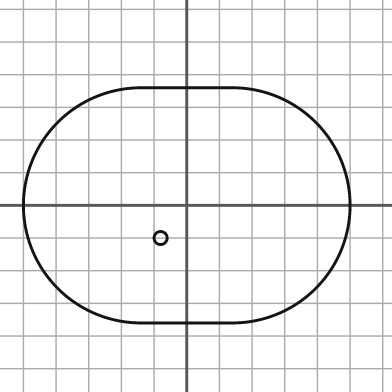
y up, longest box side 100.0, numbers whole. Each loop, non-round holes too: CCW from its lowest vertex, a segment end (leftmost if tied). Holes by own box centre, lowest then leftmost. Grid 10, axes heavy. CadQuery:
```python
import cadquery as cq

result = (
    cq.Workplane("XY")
    .moveTo(-14.0, -36.0)
    .lineTo(14.0, -36.0)
    .threePointArc((50.0, 0.0), (14.0, 36.0))
    .lineTo(-14.0, 36.0)
    .threePointArc((-50.0, 0.0), (-14.0, -36.0))
    .close()
    .moveTo(-8.0, -10.0)
    .circle(2.0)
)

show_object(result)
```